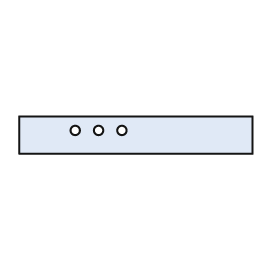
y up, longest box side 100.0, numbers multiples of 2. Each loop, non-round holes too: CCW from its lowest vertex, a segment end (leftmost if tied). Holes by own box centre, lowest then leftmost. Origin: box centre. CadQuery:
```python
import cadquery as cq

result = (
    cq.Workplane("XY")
    .moveTo(-50.0, -8.0)
    .lineTo(50.0, -8.0)
    .lineTo(50.0, 8.0)
    .lineTo(-50.0, 8.0)
    .close()
    .moveTo(-26.0, 2.0)
    .circle(2.0)
    .moveTo(-16.0, 2.0)
    .circle(2.0)
    .moveTo(-6.0, 2.0)
    .circle(2.0)
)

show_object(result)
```